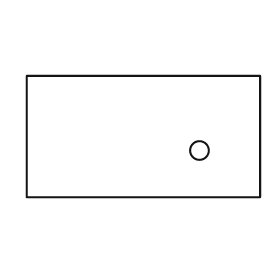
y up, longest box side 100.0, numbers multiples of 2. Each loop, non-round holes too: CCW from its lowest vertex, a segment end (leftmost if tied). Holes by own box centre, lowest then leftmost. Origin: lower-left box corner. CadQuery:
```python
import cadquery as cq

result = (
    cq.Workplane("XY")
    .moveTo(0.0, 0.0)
    .lineTo(100.0, 0.0)
    .lineTo(100.0, 52.0)
    .lineTo(0.0, 52.0)
    .close()
    .moveTo(74.0, 20.0)
    .circle(4.0)
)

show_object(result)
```